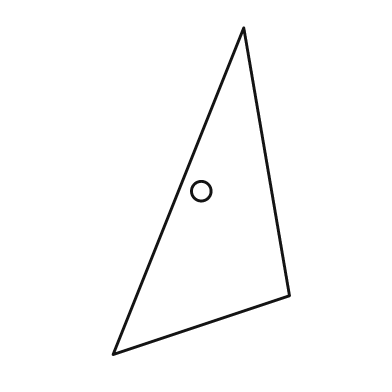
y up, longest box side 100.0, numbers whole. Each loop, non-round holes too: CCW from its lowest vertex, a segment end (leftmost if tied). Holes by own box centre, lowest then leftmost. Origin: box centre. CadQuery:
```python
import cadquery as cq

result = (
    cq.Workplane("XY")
    .moveTo(-27.0, -50.0)
    .lineTo(27.0, -32.0)
    .lineTo(13.0, 50.0)
    .close()
    .moveTo(0.0, 0.0)
    .circle(3.0)
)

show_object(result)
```